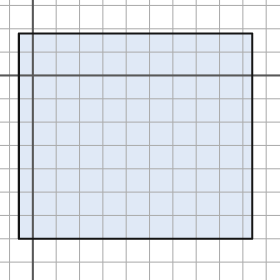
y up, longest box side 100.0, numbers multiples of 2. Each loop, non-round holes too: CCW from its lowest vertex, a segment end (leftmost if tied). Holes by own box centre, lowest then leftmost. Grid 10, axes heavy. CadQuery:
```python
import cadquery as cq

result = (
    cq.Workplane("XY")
    .moveTo(-6.0, -70.0)
    .lineTo(94.0, -70.0)
    .lineTo(94.0, 18.0)
    .lineTo(-6.0, 18.0)
    .close()
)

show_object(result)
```